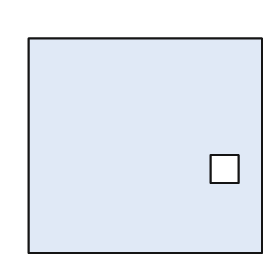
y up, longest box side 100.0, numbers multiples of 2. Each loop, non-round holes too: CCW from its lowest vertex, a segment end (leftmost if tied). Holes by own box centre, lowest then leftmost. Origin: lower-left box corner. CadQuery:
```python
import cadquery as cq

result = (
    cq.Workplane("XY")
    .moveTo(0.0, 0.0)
    .lineTo(100.0, 0.0)
    .lineTo(100.0, 92.0)
    .lineTo(0.0, 92.0)
    .close()
    .moveTo(78.0, 30.0)
    .lineTo(90.0, 30.0)
    .lineTo(90.0, 42.0)
    .lineTo(78.0, 42.0)
    .close()
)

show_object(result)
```